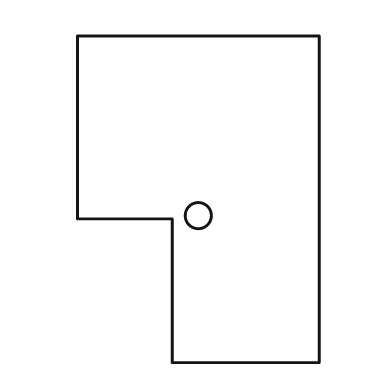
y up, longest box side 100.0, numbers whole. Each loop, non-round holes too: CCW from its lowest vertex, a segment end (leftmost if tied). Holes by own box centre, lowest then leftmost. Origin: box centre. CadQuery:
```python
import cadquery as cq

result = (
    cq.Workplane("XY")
    .moveTo(-8.0, -50.0)
    .lineTo(37.0, -50.0)
    .lineTo(37.0, 50.0)
    .lineTo(-37.0, 50.0)
    .lineTo(-37.0, -6.0)
    .lineTo(-8.0, -6.0)
    .close()
    .moveTo(0.0, -5.0)
    .circle(4.0)
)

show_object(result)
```